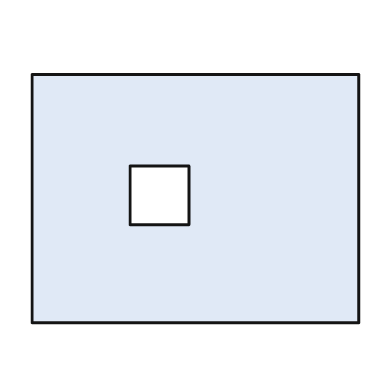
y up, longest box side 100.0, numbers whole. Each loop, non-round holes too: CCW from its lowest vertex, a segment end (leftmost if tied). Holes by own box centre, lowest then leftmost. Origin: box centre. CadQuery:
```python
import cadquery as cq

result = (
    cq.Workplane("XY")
    .moveTo(-50.0, -38.0)
    .lineTo(50.0, -38.0)
    .lineTo(50.0, 38.0)
    .lineTo(-50.0, 38.0)
    .close()
    .moveTo(-20.0, -8.0)
    .lineTo(-2.0, -8.0)
    .lineTo(-2.0, 10.0)
    .lineTo(-20.0, 10.0)
    .close()
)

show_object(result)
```